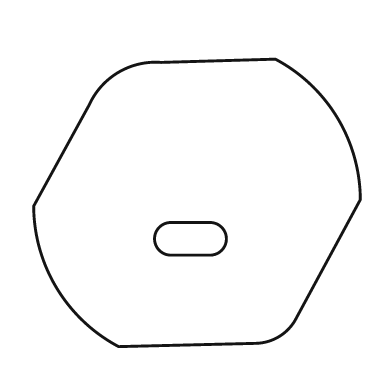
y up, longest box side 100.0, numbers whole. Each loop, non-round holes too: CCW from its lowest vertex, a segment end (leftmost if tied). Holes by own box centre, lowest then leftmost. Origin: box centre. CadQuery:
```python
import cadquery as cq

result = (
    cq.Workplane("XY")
    .moveTo(-24.0, -44.0)
    .lineTo(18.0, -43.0)
    .threePointArc((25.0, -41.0), (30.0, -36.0))
    .lineTo(50.0, 1.0)
    .threePointArc((43.0, 26.0), (24.0, 44.0))
    .lineTo(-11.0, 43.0)
    .threePointArc((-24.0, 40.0), (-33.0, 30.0))
    .lineTo(-50.0, -1.0)
    .threePointArc((-43.0, -26.0), (-24.0, -44.0))
    .close()
    .moveTo(-8.0, -16.0)
    .lineTo(4.0, -16.0)
    .threePointArc((9.0, -11.0), (4.0, -6.0))
    .lineTo(-8.0, -6.0)
    .threePointArc((-13.0, -11.0), (-8.0, -16.0))
    .close()
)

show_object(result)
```